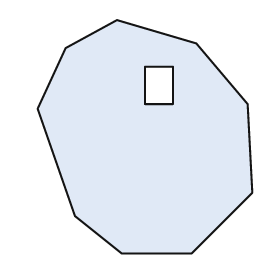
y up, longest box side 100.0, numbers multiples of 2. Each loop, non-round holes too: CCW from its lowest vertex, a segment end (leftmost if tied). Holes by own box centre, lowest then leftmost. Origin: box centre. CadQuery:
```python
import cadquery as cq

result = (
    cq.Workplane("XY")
    .moveTo(-10.0, -50.0)
    .lineTo(20.0, -50.0)
    .lineTo(46.0, -24.0)
    .lineTo(44.0, 14.0)
    .lineTo(22.0, 40.0)
    .lineTo(-12.0, 50.0)
    .lineTo(-34.0, 38.0)
    .lineTo(-46.0, 12.0)
    .lineTo(-30.0, -34.0)
    .close()
    .moveTo(0.0, 14.0)
    .lineTo(12.0, 14.0)
    .lineTo(12.0, 30.0)
    .lineTo(0.0, 30.0)
    .close()
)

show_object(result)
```